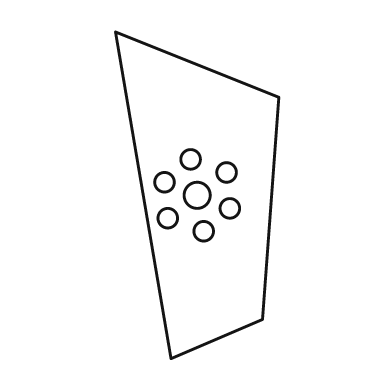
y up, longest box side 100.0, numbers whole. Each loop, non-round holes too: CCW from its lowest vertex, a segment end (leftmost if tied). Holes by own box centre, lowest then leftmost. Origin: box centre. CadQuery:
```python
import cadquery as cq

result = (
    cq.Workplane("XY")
    .moveTo(-8.0, -50.0)
    .lineTo(20.0, -38.0)
    .lineTo(25.0, 30.0)
    .lineTo(-25.0, 50.0)
    .close()
    .moveTo(2.0, -11.0)
    .circle(3.0)
    .moveTo(-9.0, -7.0)
    .circle(3.0)
    .moveTo(10.0, -4.0)
    .circle(3.0)
    .moveTo(0.0, 0.0)
    .circle(4.0)
    .moveTo(-10.0, 4.0)
    .circle(3.0)
    .moveTo(9.0, 7.0)
    .circle(3.0)
    .moveTo(-2.0, 11.0)
    .circle(3.0)
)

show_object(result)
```